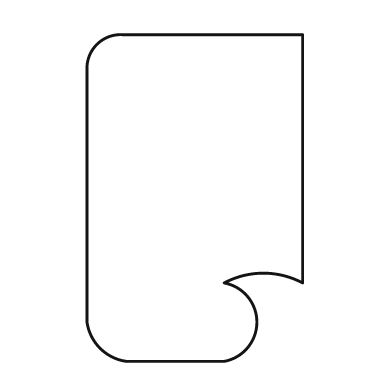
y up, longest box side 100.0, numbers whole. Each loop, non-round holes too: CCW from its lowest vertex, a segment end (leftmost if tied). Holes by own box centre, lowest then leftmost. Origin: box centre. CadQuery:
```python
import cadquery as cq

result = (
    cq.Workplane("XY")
    .moveTo(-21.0, -50.0)
    .lineTo(9.0, -50.0)
    .threePointArc((19.0, -38.0), (9.0, -26.0))
    .threePointArc((21.0, -23.0), (33.0, -26.0))
    .lineTo(33.0, 50.0)
    .lineTo(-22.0, 50.0)
    .threePointArc((-30.0, 47.0), (-33.0, 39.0))
    .lineTo(-33.0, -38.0)
    .threePointArc((-29.0, -46.0), (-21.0, -50.0))
    .close()
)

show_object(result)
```